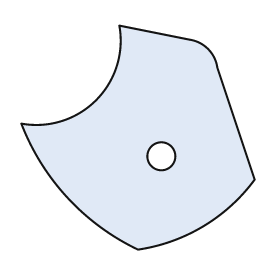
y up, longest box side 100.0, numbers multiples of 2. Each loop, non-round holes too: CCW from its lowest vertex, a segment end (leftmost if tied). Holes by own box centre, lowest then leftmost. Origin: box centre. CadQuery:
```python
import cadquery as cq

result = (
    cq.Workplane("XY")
    .moveTo(0.0, -48.0)
    .threePointArc((28.0, -38.0), (50.0, -18.0))
    .lineTo(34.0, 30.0)
    .threePointArc((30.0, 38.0), (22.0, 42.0))
    .lineTo(-8.0, 48.0)
    .threePointArc((-18.0, 16.0), (-50.0, 6.0))
    .threePointArc((-30.0, -26.0), (0.0, -48.0))
    .close()
    .moveTo(10.0, -8.0)
    .circle(6.0)
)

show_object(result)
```